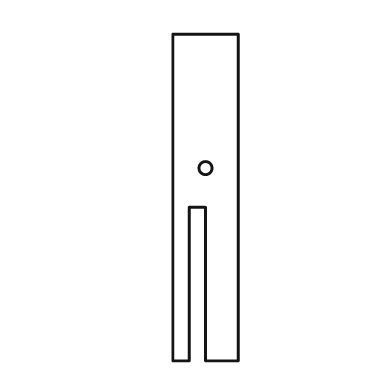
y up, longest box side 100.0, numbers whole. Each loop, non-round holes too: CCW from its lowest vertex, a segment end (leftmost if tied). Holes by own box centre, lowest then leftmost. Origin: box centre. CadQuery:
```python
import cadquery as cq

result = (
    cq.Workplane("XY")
    .moveTo(-10.0, -50.0)
    .lineTo(-5.0, -50.0)
    .lineTo(-5.0, -3.0)
    .lineTo(0.0, -3.0)
    .lineTo(0.0, -50.0)
    .lineTo(10.0, -50.0)
    .lineTo(10.0, 50.0)
    .lineTo(-10.0, 50.0)
    .close()
    .moveTo(0.0, 9.0)
    .circle(2.0)
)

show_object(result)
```